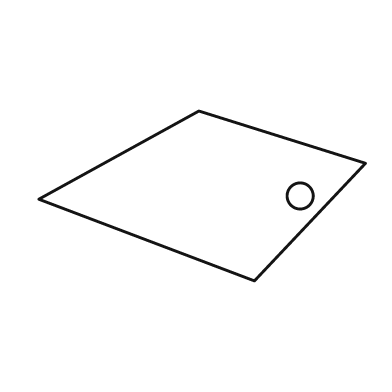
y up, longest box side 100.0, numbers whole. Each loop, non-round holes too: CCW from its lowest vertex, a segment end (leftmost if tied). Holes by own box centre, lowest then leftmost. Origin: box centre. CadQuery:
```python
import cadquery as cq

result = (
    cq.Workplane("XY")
    .moveTo(16.0, -26.0)
    .lineTo(50.0, 10.0)
    .lineTo(-1.0, 26.0)
    .lineTo(-50.0, -1.0)
    .close()
    .moveTo(30.0, 0.0)
    .circle(4.0)
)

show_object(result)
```